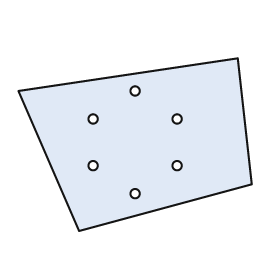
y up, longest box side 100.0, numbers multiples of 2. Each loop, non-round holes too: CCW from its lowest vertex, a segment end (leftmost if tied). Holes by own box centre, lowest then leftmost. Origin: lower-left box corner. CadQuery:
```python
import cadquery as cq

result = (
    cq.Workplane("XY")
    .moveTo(26.0, 0.0)
    .lineTo(100.0, 20.0)
    .lineTo(94.0, 74.0)
    .lineTo(0.0, 60.0)
    .close()
    .moveTo(50.0, 16.0)
    .circle(2.0)
    .moveTo(32.0, 28.0)
    .circle(2.0)
    .moveTo(68.0, 28.0)
    .circle(2.0)
    .moveTo(32.0, 48.0)
    .circle(2.0)
    .moveTo(68.0, 48.0)
    .circle(2.0)
    .moveTo(50.0, 60.0)
    .circle(2.0)
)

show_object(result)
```